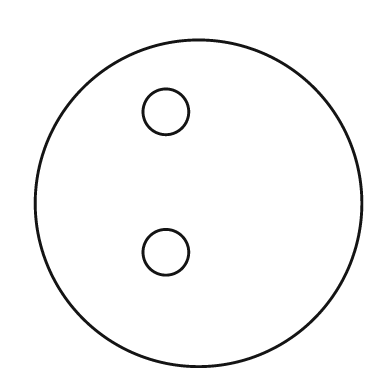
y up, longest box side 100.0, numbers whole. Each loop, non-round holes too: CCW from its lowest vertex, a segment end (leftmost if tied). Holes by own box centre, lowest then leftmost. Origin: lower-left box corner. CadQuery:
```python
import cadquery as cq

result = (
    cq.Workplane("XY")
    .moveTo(50.0, 50.0)
    .circle(50.0)
    .moveTo(40.0, 35.0)
    .circle(7.0)
    .moveTo(40.0, 78.0)
    .circle(7.0)
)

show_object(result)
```